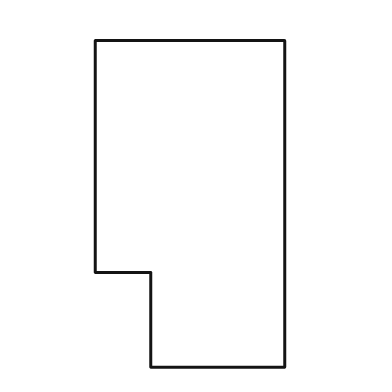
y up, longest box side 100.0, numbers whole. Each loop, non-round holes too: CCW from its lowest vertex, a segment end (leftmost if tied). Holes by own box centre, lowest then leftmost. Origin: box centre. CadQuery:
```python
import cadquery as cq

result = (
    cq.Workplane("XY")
    .moveTo(-12.0, -50.0)
    .lineTo(29.0, -50.0)
    .lineTo(29.0, 50.0)
    .lineTo(-29.0, 50.0)
    .lineTo(-29.0, -21.0)
    .lineTo(-12.0, -21.0)
    .close()
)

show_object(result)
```